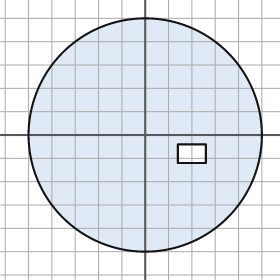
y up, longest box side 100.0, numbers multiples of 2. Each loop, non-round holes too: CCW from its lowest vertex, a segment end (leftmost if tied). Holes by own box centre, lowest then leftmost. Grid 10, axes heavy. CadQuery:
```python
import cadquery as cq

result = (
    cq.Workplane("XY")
    .moveTo(0.0, 0.0)
    .circle(50.0)
    .moveTo(14.0, -12.0)
    .lineTo(26.0, -12.0)
    .lineTo(26.0, -4.0)
    .lineTo(14.0, -4.0)
    .close()
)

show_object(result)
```